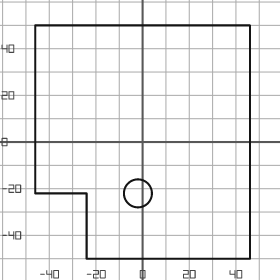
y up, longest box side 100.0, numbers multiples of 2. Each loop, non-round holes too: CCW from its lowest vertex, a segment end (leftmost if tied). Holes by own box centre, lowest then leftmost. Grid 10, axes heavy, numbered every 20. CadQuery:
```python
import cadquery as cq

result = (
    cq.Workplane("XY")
    .moveTo(-24.0, -50.0)
    .lineTo(46.0, -50.0)
    .lineTo(46.0, 50.0)
    .lineTo(-46.0, 50.0)
    .lineTo(-46.0, -22.0)
    .lineTo(-24.0, -22.0)
    .close()
    .moveTo(-2.0, -22.0)
    .circle(6.0)
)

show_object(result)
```